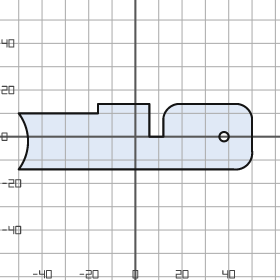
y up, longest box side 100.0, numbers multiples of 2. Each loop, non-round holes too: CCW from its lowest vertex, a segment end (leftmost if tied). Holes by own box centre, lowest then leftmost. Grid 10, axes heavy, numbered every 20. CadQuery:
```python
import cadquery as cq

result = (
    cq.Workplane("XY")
    .moveTo(-50.0, -14.0)
    .lineTo(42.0, -14.0)
    .threePointArc((48.0, -12.0), (50.0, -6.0))
    .lineTo(50.0, 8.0)
    .threePointArc((48.0, 12.0), (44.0, 14.0))
    .lineTo(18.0, 14.0)
    .threePointArc((14.0, 12.0), (12.0, 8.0))
    .lineTo(12.0, 0.0)
    .lineTo(6.0, 0.0)
    .lineTo(6.0, 14.0)
    .lineTo(-16.0, 14.0)
    .lineTo(-16.0, 10.0)
    .lineTo(-50.0, 10.0)
    .threePointArc((-46.0, -2.0), (-50.0, -14.0))
    .close()
    .moveTo(38.0, 0.0)
    .circle(2.0)
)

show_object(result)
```